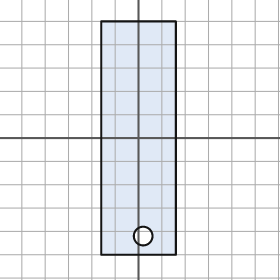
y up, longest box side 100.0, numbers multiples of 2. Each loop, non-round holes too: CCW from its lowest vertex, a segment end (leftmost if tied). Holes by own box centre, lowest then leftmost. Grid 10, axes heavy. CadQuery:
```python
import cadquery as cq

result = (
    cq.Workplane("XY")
    .moveTo(-16.0, -50.0)
    .lineTo(16.0, -50.0)
    .lineTo(16.0, 50.0)
    .lineTo(-16.0, 50.0)
    .close()
    .moveTo(2.0, -42.0)
    .circle(4.0)
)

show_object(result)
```